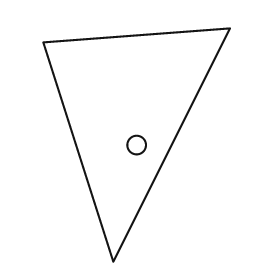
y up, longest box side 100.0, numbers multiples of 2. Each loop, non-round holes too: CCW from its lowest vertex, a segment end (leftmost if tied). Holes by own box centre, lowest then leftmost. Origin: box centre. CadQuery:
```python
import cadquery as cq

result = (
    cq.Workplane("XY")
    .moveTo(-10.0, -50.0)
    .lineTo(40.0, 50.0)
    .lineTo(-40.0, 44.0)
    .close()
    .moveTo(0.0, 0.0)
    .circle(4.0)
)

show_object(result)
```